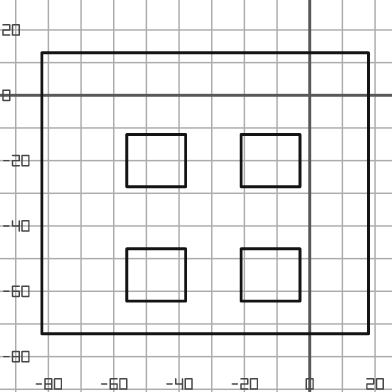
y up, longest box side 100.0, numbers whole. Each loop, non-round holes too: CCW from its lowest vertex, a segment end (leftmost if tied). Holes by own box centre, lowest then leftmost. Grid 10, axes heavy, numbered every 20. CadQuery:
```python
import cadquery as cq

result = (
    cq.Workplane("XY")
    .moveTo(-82.0, -73.0)
    .lineTo(18.0, -73.0)
    .lineTo(18.0, 13.0)
    .lineTo(-82.0, 13.0)
    .close()
    .moveTo(-56.0, -63.0)
    .lineTo(-38.0, -63.0)
    .lineTo(-38.0, -47.0)
    .lineTo(-56.0, -47.0)
    .close()
    .moveTo(-21.0, -63.0)
    .lineTo(-3.0, -63.0)
    .lineTo(-3.0, -47.0)
    .lineTo(-21.0, -47.0)
    .close()
    .moveTo(-56.0, -28.0)
    .lineTo(-38.0, -28.0)
    .lineTo(-38.0, -12.0)
    .lineTo(-56.0, -12.0)
    .close()
    .moveTo(-21.0, -28.0)
    .lineTo(-3.0, -28.0)
    .lineTo(-3.0, -12.0)
    .lineTo(-21.0, -12.0)
    .close()
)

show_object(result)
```